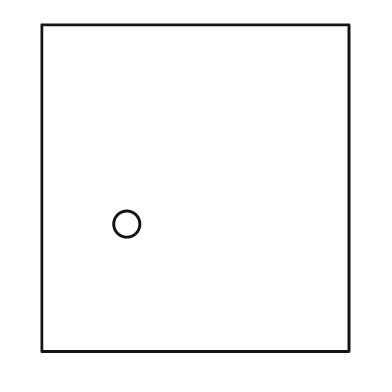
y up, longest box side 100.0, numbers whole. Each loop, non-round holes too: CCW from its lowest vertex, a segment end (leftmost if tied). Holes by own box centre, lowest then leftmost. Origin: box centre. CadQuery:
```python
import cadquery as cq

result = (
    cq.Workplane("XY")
    .moveTo(-47.0, -50.0)
    .lineTo(47.0, -50.0)
    .lineTo(47.0, 50.0)
    .lineTo(-47.0, 50.0)
    .close()
    .moveTo(-21.0, -11.0)
    .circle(4.0)
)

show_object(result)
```